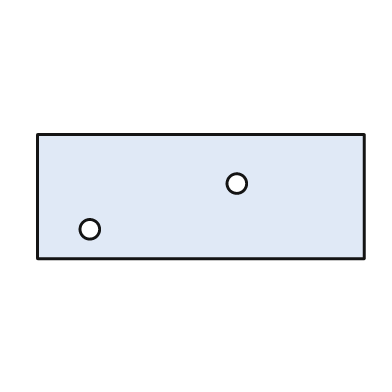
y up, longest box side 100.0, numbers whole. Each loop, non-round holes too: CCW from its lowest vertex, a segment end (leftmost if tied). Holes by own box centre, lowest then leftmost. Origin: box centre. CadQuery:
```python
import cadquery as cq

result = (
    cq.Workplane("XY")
    .moveTo(-50.0, -19.0)
    .lineTo(50.0, -19.0)
    .lineTo(50.0, 19.0)
    .lineTo(-50.0, 19.0)
    .close()
    .moveTo(-34.0, -10.0)
    .circle(3.0)
    .moveTo(11.0, 4.0)
    .circle(3.0)
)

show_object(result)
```